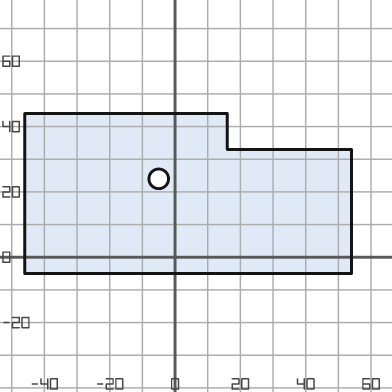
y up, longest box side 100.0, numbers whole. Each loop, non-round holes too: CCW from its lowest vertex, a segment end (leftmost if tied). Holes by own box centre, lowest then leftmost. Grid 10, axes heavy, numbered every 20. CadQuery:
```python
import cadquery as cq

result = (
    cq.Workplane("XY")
    .moveTo(-46.0, -5.0)
    .lineTo(54.0, -5.0)
    .lineTo(54.0, 33.0)
    .lineTo(16.0, 33.0)
    .lineTo(16.0, 44.0)
    .lineTo(-46.0, 44.0)
    .close()
    .moveTo(-5.0, 24.0)
    .circle(3.0)
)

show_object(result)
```